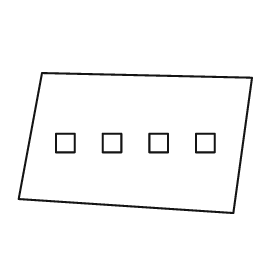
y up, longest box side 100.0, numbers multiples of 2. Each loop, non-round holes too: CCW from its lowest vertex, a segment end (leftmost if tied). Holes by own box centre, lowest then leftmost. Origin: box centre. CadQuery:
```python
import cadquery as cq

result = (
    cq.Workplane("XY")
    .moveTo(42.0, -30.0)
    .lineTo(50.0, 28.0)
    .lineTo(-40.0, 30.0)
    .lineTo(-50.0, -24.0)
    .close()
    .moveTo(-34.0, -4.0)
    .lineTo(-26.0, -4.0)
    .lineTo(-26.0, 4.0)
    .lineTo(-34.0, 4.0)
    .close()
    .moveTo(-14.0, -4.0)
    .lineTo(-6.0, -4.0)
    .lineTo(-6.0, 4.0)
    .lineTo(-14.0, 4.0)
    .close()
    .moveTo(6.0, -4.0)
    .lineTo(14.0, -4.0)
    .lineTo(14.0, 4.0)
    .lineTo(6.0, 4.0)
    .close()
    .moveTo(26.0, -4.0)
    .lineTo(34.0, -4.0)
    .lineTo(34.0, 4.0)
    .lineTo(26.0, 4.0)
    .close()
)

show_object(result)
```